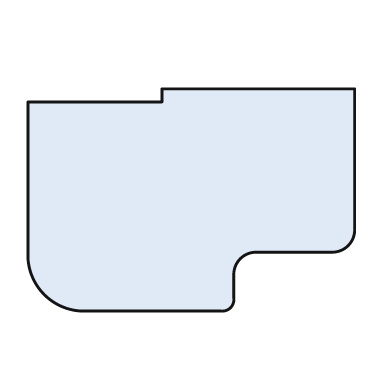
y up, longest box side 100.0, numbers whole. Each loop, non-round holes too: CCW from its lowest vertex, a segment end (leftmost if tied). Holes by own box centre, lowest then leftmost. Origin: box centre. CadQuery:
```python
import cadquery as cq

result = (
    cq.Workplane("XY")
    .moveTo(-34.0, -34.0)
    .lineTo(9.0, -34.0)
    .threePointArc((12.0, -33.0), (13.0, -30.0))
    .lineTo(13.0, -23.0)
    .threePointArc((15.0, -18.0), (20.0, -16.0))
    .lineTo(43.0, -16.0)
    .threePointArc((48.0, -14.0), (50.0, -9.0))
    .lineTo(50.0, 34.0)
    .lineTo(-9.0, 34.0)
    .lineTo(-9.0, 30.0)
    .lineTo(-50.0, 30.0)
    .lineTo(-50.0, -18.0)
    .threePointArc((-45.0, -29.0), (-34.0, -34.0))
    .close()
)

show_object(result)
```